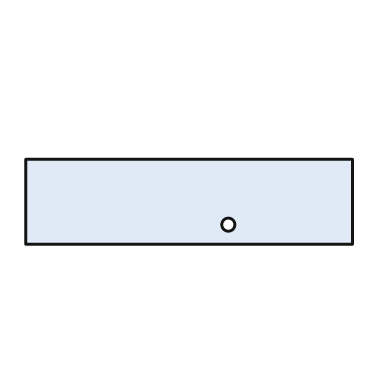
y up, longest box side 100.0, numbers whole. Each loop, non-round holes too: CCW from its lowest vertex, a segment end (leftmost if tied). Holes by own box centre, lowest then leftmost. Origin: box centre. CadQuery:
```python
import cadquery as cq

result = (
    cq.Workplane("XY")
    .moveTo(-50.0, -13.0)
    .lineTo(50.0, -13.0)
    .lineTo(50.0, 13.0)
    .lineTo(-50.0, 13.0)
    .close()
    .moveTo(12.0, -7.0)
    .circle(2.0)
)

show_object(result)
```